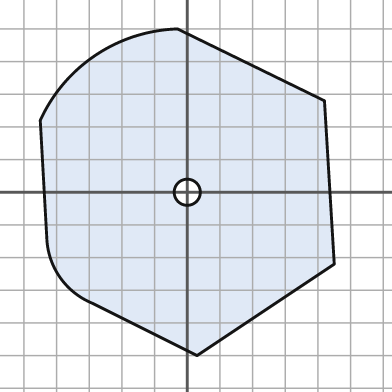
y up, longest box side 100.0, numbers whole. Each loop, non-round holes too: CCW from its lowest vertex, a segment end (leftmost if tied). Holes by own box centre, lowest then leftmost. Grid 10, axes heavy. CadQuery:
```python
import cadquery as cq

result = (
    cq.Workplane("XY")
    .moveTo(3.0, -50.0)
    .lineTo(45.0, -22.0)
    .lineTo(42.0, 28.0)
    .lineTo(-3.0, 50.0)
    .threePointArc((-28.0, 42.0), (-45.0, 22.0))
    .lineTo(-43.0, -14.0)
    .threePointArc((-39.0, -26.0), (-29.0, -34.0))
    .close()
    .moveTo(0.0, 0.0)
    .circle(4.0)
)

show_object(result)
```